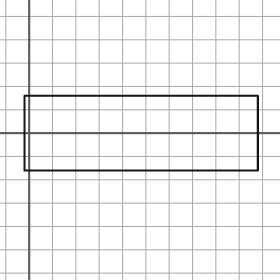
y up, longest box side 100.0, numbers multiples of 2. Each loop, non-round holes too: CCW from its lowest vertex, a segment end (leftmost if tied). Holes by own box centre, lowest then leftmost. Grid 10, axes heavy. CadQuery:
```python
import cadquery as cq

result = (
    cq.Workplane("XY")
    .moveTo(-2.0, -16.0)
    .lineTo(98.0, -16.0)
    .lineTo(98.0, 16.0)
    .lineTo(-2.0, 16.0)
    .close()
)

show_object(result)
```